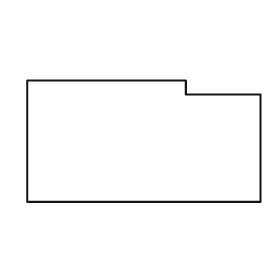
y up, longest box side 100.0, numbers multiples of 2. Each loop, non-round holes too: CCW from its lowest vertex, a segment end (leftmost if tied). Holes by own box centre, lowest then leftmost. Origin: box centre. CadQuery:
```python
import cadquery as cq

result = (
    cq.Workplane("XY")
    .moveTo(-50.0, -26.0)
    .lineTo(50.0, -26.0)
    .lineTo(50.0, 20.0)
    .lineTo(18.0, 20.0)
    .lineTo(18.0, 26.0)
    .lineTo(-50.0, 26.0)
    .close()
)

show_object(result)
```